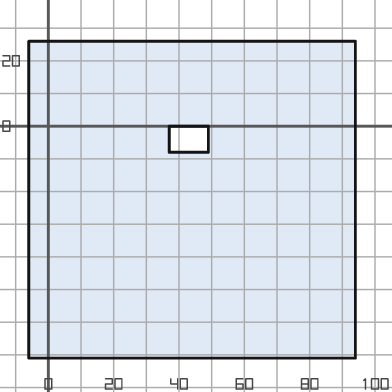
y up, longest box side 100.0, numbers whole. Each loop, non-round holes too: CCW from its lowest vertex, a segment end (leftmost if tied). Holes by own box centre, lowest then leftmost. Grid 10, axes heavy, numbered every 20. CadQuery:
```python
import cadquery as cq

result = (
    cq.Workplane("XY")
    .moveTo(-6.0, -71.0)
    .lineTo(94.0, -71.0)
    .lineTo(94.0, 26.0)
    .lineTo(-6.0, 26.0)
    .close()
    .moveTo(37.0, -8.0)
    .lineTo(49.0, -8.0)
    .lineTo(49.0, 0.0)
    .lineTo(37.0, 0.0)
    .close()
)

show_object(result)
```